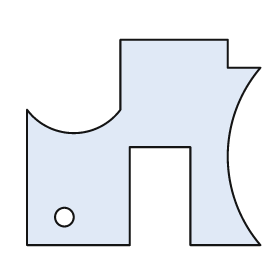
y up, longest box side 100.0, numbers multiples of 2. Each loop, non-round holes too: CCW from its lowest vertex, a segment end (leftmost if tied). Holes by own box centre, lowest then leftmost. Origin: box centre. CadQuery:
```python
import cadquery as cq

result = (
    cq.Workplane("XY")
    .moveTo(-50.0, -44.0)
    .lineTo(-6.0, -44.0)
    .lineTo(-6.0, -2.0)
    .lineTo(20.0, -2.0)
    .lineTo(20.0, -44.0)
    .lineTo(50.0, -44.0)
    .threePointArc((36.0, -6.0), (50.0, 32.0))
    .lineTo(36.0, 32.0)
    .lineTo(36.0, 44.0)
    .lineTo(-10.0, 44.0)
    .lineTo(-10.0, 14.0)
    .threePointArc((-30.0, 4.0), (-50.0, 14.0))
    .close()
    .moveTo(-34.0, -32.0)
    .circle(4.0)
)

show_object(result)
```